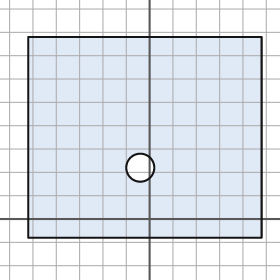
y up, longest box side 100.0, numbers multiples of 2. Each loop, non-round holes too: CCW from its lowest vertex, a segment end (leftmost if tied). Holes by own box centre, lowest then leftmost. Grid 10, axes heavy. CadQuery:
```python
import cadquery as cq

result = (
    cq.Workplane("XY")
    .moveTo(-52.0, -8.0)
    .lineTo(48.0, -8.0)
    .lineTo(48.0, 78.0)
    .lineTo(-52.0, 78.0)
    .close()
    .moveTo(-4.0, 22.0)
    .circle(6.0)
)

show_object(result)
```